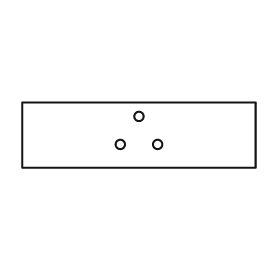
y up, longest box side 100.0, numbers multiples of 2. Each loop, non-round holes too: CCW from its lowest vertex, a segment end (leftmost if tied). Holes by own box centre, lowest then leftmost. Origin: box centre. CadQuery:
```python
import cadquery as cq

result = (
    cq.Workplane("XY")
    .moveTo(-50.0, -14.0)
    .lineTo(50.0, -14.0)
    .lineTo(50.0, 14.0)
    .lineTo(-50.0, 14.0)
    .close()
    .moveTo(-8.0, -4.0)
    .circle(2.0)
    .moveTo(8.0, -4.0)
    .circle(2.0)
    .moveTo(0.0, 8.0)
    .circle(2.0)
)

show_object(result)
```